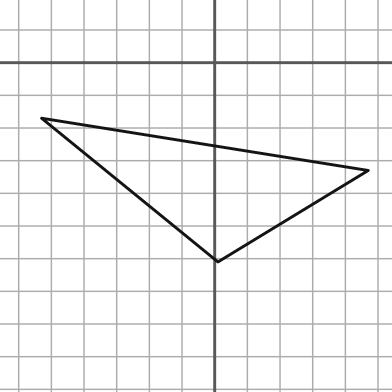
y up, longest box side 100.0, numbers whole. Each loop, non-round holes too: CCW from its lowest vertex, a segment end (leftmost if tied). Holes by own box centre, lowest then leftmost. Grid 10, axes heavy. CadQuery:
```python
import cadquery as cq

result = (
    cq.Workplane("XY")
    .moveTo(1.0, -61.0)
    .lineTo(47.0, -33.0)
    .lineTo(-53.0, -17.0)
    .close()
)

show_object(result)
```